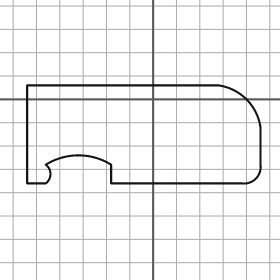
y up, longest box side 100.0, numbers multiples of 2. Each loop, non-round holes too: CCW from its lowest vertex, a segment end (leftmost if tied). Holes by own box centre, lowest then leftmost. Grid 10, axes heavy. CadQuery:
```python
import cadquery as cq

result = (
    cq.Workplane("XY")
    .moveTo(-54.0, -36.0)
    .lineTo(-46.0, -36.0)
    .threePointArc((-44.0, -32.0), (-46.0, -28.0))
    .threePointArc((-32.0, -24.0), (-18.0, -28.0))
    .lineTo(-18.0, -36.0)
    .lineTo(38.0, -36.0)
    .threePointArc((44.0, -34.0), (46.0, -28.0))
    .lineTo(46.0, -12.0)
    .threePointArc((40.0, 0.0), (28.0, 6.0))
    .lineTo(-54.0, 6.0)
    .close()
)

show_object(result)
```